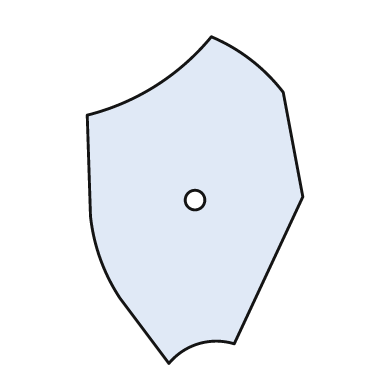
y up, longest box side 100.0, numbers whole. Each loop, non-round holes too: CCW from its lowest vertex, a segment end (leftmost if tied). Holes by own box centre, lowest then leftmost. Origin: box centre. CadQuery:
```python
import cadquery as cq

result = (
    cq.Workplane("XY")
    .moveTo(-8.0, -50.0)
    .threePointArc((1.0, -44.0), (12.0, -44.0))
    .lineTo(33.0, 1.0)
    .lineTo(27.0, 33.0)
    .threePointArc((17.0, 43.0), (5.0, 50.0))
    .threePointArc((-12.0, 35.0), (-33.0, 26.0))
    .lineTo(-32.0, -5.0)
    .threePointArc((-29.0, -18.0), (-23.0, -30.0))
    .close()
    .moveTo(0.0, 0.0)
    .circle(3.0)
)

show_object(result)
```